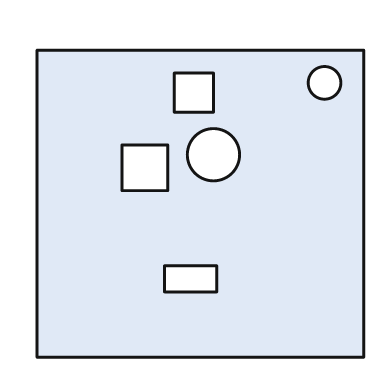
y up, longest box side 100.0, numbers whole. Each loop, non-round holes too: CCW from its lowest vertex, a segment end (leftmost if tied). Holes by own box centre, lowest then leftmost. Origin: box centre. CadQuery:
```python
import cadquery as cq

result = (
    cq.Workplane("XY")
    .moveTo(-50.0, -47.0)
    .lineTo(50.0, -47.0)
    .lineTo(50.0, 47.0)
    .lineTo(-50.0, 47.0)
    .close()
    .moveTo(-11.0, -27.0)
    .lineTo(5.0, -27.0)
    .lineTo(5.0, -19.0)
    .lineTo(-11.0, -19.0)
    .close()
    .moveTo(-24.0, 4.0)
    .lineTo(-10.0, 4.0)
    .lineTo(-10.0, 18.0)
    .lineTo(-24.0, 18.0)
    .close()
    .moveTo(4.0, 15.0)
    .circle(8.0)
    .moveTo(-8.0, 28.0)
    .lineTo(4.0, 28.0)
    .lineTo(4.0, 40.0)
    .lineTo(-8.0, 40.0)
    .close()
    .moveTo(38.0, 37.0)
    .circle(5.0)
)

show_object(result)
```